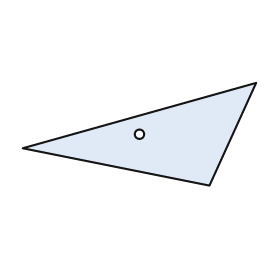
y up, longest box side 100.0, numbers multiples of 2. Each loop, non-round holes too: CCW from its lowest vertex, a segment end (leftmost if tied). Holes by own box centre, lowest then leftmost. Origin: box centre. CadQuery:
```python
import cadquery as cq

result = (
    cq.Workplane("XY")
    .moveTo(30.0, -22.0)
    .lineTo(50.0, 22.0)
    .lineTo(-50.0, -6.0)
    .close()
    .moveTo(0.0, 0.0)
    .circle(2.0)
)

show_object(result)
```